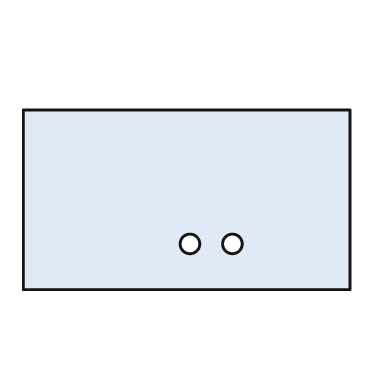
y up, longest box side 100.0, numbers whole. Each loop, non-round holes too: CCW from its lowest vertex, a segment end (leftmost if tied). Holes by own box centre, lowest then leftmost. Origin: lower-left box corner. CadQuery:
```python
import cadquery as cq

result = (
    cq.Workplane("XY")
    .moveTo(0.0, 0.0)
    .lineTo(100.0, 0.0)
    .lineTo(100.0, 55.0)
    .lineTo(0.0, 55.0)
    .close()
    .moveTo(51.0, 14.0)
    .circle(3.0)
    .moveTo(64.0, 14.0)
    .circle(3.0)
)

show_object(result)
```